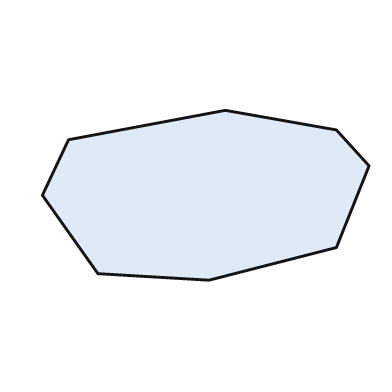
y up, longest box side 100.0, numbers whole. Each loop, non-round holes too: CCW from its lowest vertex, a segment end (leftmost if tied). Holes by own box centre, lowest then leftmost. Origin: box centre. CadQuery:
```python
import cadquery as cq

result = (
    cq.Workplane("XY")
    .moveTo(1.0, -26.0)
    .lineTo(40.0, -16.0)
    .lineTo(50.0, 9.0)
    .lineTo(40.0, 20.0)
    .lineTo(6.0, 26.0)
    .lineTo(-42.0, 17.0)
    .lineTo(-50.0, 0.0)
    .lineTo(-33.0, -24.0)
    .close()
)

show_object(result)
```